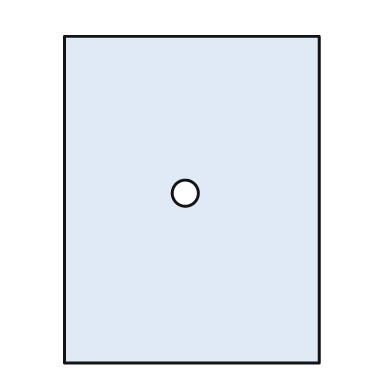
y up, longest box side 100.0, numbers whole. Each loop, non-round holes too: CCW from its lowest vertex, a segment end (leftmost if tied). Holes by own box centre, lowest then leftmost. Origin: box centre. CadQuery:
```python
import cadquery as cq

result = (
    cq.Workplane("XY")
    .moveTo(-39.0, -50.0)
    .lineTo(39.0, -50.0)
    .lineTo(39.0, 50.0)
    .lineTo(-39.0, 50.0)
    .close()
    .moveTo(-2.0, 2.0)
    .circle(4.0)
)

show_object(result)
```